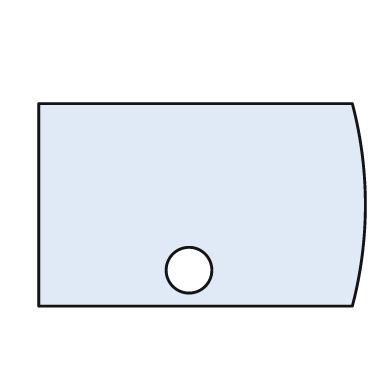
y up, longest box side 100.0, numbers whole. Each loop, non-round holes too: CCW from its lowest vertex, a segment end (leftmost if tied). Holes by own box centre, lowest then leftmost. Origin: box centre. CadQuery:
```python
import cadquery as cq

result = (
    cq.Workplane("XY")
    .moveTo(-50.0, -31.0)
    .lineTo(46.0, -31.0)
    .threePointArc((50.0, 0.0), (46.0, 31.0))
    .lineTo(-50.0, 31.0)
    .close()
    .moveTo(-4.0, -20.0)
    .circle(7.0)
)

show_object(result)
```